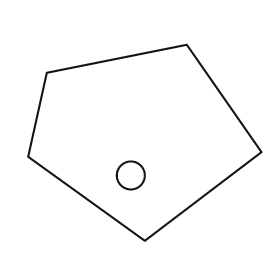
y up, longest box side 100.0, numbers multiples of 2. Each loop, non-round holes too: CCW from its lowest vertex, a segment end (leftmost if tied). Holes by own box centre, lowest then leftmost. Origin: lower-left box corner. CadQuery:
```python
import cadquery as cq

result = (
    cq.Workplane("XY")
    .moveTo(50.0, 0.0)
    .lineTo(100.0, 38.0)
    .lineTo(68.0, 84.0)
    .lineTo(8.0, 72.0)
    .lineTo(0.0, 36.0)
    .close()
    .moveTo(44.0, 28.0)
    .circle(6.0)
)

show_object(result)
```